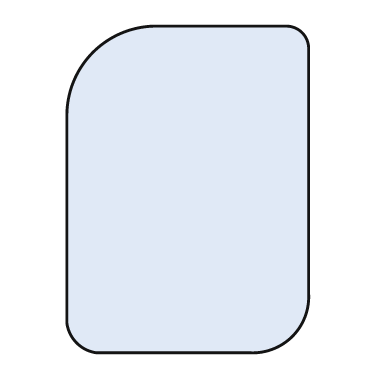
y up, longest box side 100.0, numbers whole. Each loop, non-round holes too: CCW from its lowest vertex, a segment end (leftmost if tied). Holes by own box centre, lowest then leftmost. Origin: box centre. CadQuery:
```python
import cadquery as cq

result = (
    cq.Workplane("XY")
    .moveTo(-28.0, -50.0)
    .lineTo(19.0, -50.0)
    .threePointArc((32.0, -45.0), (37.0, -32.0))
    .lineTo(37.0, 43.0)
    .threePointArc((35.0, 48.0), (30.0, 50.0))
    .lineTo(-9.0, 50.0)
    .threePointArc((-29.0, 42.0), (-37.0, 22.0))
    .lineTo(-37.0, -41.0)
    .threePointArc((-34.0, -47.0), (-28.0, -50.0))
    .close()
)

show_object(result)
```